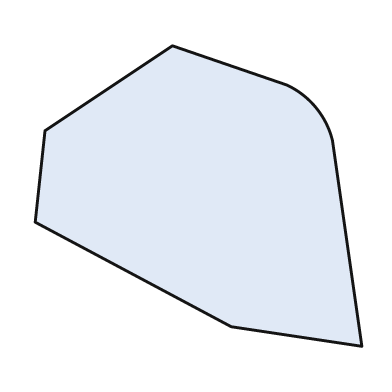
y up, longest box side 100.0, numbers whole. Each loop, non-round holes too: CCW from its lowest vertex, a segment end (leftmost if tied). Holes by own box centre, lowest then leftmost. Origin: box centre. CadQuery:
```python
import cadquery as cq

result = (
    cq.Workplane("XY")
    .moveTo(50.0, -46.0)
    .lineTo(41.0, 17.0)
    .threePointArc((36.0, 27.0), (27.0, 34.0))
    .lineTo(-8.0, 46.0)
    .lineTo(-47.0, 20.0)
    .lineTo(-50.0, -8.0)
    .lineTo(10.0, -40.0)
    .close()
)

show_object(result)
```